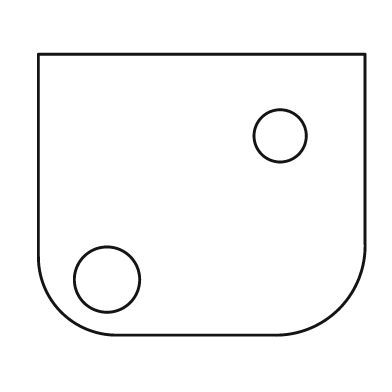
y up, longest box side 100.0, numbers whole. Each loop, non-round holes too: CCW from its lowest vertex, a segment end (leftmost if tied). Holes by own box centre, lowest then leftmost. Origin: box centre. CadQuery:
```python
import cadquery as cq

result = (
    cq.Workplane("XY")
    .moveTo(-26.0, -43.0)
    .lineTo(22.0, -43.0)
    .threePointArc((42.0, -35.0), (50.0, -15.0))
    .lineTo(50.0, 43.0)
    .lineTo(-50.0, 43.0)
    .lineTo(-50.0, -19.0)
    .threePointArc((-43.0, -36.0), (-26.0, -43.0))
    .close()
    .moveTo(-29.0, -26.0)
    .circle(10.0)
    .moveTo(24.0, 18.0)
    .circle(8.0)
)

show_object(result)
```